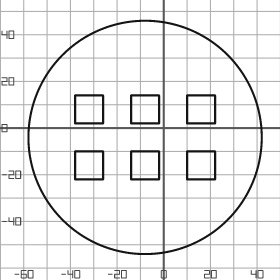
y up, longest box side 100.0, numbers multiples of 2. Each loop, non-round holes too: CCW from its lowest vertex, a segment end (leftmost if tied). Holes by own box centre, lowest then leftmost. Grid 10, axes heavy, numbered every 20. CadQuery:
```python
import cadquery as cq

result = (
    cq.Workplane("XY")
    .moveTo(-8.0, -4.0)
    .circle(50.0)
    .moveTo(-38.0, -22.0)
    .lineTo(-26.0, -22.0)
    .lineTo(-26.0, -10.0)
    .lineTo(-38.0, -10.0)
    .close()
    .moveTo(-14.0, -22.0)
    .lineTo(-2.0, -22.0)
    .lineTo(-2.0, -10.0)
    .lineTo(-14.0, -10.0)
    .close()
    .moveTo(10.0, -22.0)
    .lineTo(22.0, -22.0)
    .lineTo(22.0, -10.0)
    .lineTo(10.0, -10.0)
    .close()
    .moveTo(-38.0, 2.0)
    .lineTo(-26.0, 2.0)
    .lineTo(-26.0, 14.0)
    .lineTo(-38.0, 14.0)
    .close()
    .moveTo(-14.0, 2.0)
    .lineTo(-2.0, 2.0)
    .lineTo(-2.0, 14.0)
    .lineTo(-14.0, 14.0)
    .close()
    .moveTo(10.0, 2.0)
    .lineTo(22.0, 2.0)
    .lineTo(22.0, 14.0)
    .lineTo(10.0, 14.0)
    .close()
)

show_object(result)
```